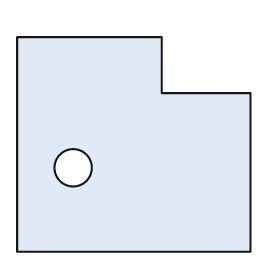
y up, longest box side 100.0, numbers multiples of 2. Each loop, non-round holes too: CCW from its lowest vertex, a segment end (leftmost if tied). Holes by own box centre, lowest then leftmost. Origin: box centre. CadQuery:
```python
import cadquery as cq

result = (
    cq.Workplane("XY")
    .moveTo(-50.0, -46.0)
    .lineTo(50.0, -46.0)
    .lineTo(50.0, 22.0)
    .lineTo(12.0, 22.0)
    .lineTo(12.0, 46.0)
    .lineTo(-50.0, 46.0)
    .close()
    .moveTo(-26.0, -10.0)
    .circle(8.0)
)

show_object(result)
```